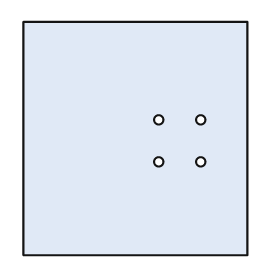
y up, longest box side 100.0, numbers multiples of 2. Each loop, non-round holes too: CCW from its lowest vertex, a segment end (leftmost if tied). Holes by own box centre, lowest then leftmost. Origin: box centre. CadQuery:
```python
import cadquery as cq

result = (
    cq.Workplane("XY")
    .moveTo(-48.0, -50.0)
    .lineTo(48.0, -50.0)
    .lineTo(48.0, 50.0)
    .lineTo(-48.0, 50.0)
    .close()
    .moveTo(10.0, -10.0)
    .circle(2.0)
    .moveTo(28.0, -10.0)
    .circle(2.0)
    .moveTo(10.0, 8.0)
    .circle(2.0)
    .moveTo(28.0, 8.0)
    .circle(2.0)
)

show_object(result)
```